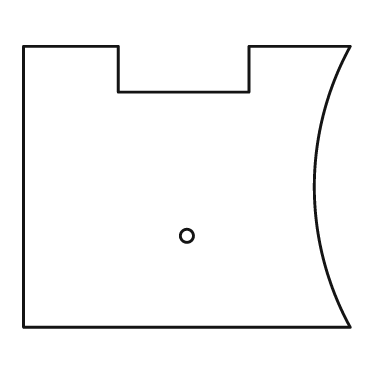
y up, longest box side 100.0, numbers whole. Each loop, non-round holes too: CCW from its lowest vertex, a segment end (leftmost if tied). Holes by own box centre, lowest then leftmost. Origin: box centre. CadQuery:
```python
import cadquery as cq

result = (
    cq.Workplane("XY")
    .moveTo(-50.0, -43.0)
    .lineTo(50.0, -43.0)
    .threePointArc((39.0, 0.0), (50.0, 43.0))
    .lineTo(19.0, 43.0)
    .lineTo(19.0, 29.0)
    .lineTo(-21.0, 29.0)
    .lineTo(-21.0, 43.0)
    .lineTo(-50.0, 43.0)
    .close()
    .moveTo(0.0, -15.0)
    .circle(2.0)
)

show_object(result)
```